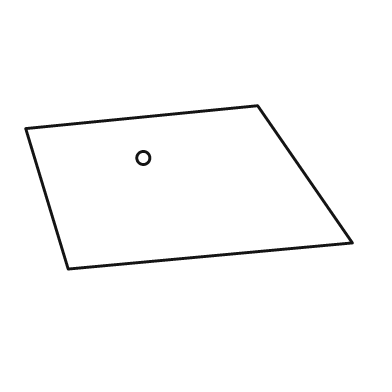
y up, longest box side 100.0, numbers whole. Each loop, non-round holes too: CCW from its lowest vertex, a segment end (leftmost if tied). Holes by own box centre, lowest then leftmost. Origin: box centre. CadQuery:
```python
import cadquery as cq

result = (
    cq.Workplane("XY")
    .moveTo(-37.0, -25.0)
    .lineTo(50.0, -17.0)
    .lineTo(21.0, 25.0)
    .lineTo(-50.0, 18.0)
    .close()
    .moveTo(-14.0, 9.0)
    .circle(2.0)
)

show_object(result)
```